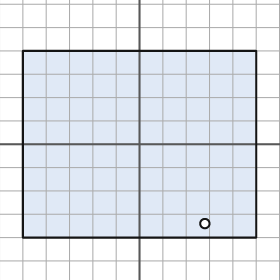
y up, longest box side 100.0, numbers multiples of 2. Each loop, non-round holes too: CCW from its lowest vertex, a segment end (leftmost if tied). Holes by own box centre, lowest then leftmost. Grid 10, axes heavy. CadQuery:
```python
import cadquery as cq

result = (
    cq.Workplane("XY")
    .moveTo(-50.0, -40.0)
    .lineTo(50.0, -40.0)
    .lineTo(50.0, 40.0)
    .lineTo(-50.0, 40.0)
    .close()
    .moveTo(28.0, -34.0)
    .circle(2.0)
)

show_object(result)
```